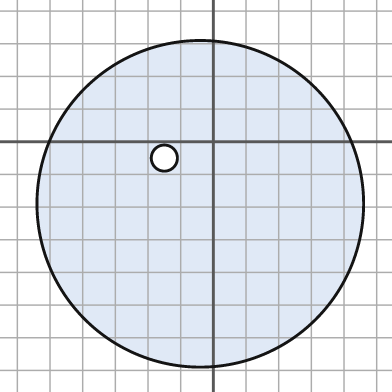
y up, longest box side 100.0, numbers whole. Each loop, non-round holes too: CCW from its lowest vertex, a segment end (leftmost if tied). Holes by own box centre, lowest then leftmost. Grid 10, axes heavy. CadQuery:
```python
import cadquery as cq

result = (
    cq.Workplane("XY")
    .moveTo(-4.0, -19.0)
    .circle(50.0)
    .moveTo(-15.0, -5.0)
    .circle(4.0)
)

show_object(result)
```